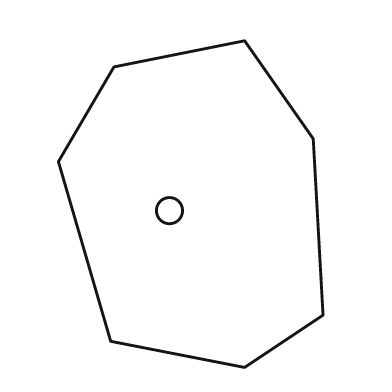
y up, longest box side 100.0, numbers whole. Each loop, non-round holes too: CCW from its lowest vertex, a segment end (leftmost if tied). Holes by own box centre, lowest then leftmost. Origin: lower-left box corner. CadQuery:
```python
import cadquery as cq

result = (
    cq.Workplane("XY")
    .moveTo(57.0, 0.0)
    .lineTo(81.0, 16.0)
    .lineTo(78.0, 70.0)
    .lineTo(57.0, 100.0)
    .lineTo(17.0, 92.0)
    .lineTo(0.0, 63.0)
    .lineTo(16.0, 8.0)
    .close()
    .moveTo(34.0, 48.0)
    .circle(4.0)
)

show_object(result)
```